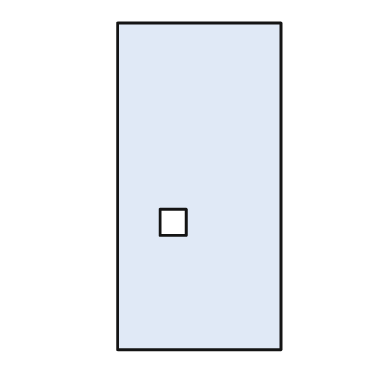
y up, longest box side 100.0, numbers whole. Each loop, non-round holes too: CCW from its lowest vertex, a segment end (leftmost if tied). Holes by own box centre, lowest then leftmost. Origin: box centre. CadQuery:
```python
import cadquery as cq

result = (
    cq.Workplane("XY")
    .moveTo(-25.0, -50.0)
    .lineTo(25.0, -50.0)
    .lineTo(25.0, 50.0)
    .lineTo(-25.0, 50.0)
    .close()
    .moveTo(-12.0, -15.0)
    .lineTo(-4.0, -15.0)
    .lineTo(-4.0, -7.0)
    .lineTo(-12.0, -7.0)
    .close()
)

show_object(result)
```